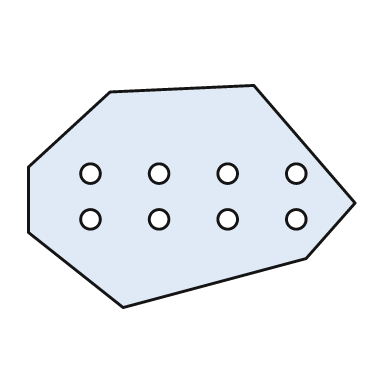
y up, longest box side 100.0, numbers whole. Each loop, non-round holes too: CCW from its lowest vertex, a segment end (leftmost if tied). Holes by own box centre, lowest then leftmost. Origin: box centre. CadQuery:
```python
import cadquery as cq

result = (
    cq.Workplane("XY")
    .moveTo(-21.0, -34.0)
    .lineTo(35.0, -19.0)
    .lineTo(50.0, -2.0)
    .lineTo(19.0, 34.0)
    .lineTo(-25.0, 32.0)
    .lineTo(-50.0, 9.0)
    .lineTo(-50.0, -11.0)
    .close()
    .moveTo(-31.0, -7.0)
    .circle(3.0)
    .moveTo(-10.0, -7.0)
    .circle(3.0)
    .moveTo(11.0, -7.0)
    .circle(3.0)
    .moveTo(32.0, -7.0)
    .circle(3.0)
    .moveTo(-31.0, 7.0)
    .circle(3.0)
    .moveTo(-10.0, 7.0)
    .circle(3.0)
    .moveTo(11.0, 7.0)
    .circle(3.0)
    .moveTo(32.0, 7.0)
    .circle(3.0)
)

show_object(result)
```